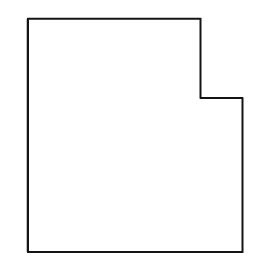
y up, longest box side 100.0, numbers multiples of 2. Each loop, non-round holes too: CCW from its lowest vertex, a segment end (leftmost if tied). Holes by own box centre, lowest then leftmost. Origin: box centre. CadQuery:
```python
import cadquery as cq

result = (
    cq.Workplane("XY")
    .moveTo(-46.0, -50.0)
    .lineTo(46.0, -50.0)
    .lineTo(46.0, 16.0)
    .lineTo(28.0, 16.0)
    .lineTo(28.0, 50.0)
    .lineTo(-46.0, 50.0)
    .close()
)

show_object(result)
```